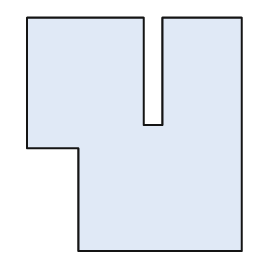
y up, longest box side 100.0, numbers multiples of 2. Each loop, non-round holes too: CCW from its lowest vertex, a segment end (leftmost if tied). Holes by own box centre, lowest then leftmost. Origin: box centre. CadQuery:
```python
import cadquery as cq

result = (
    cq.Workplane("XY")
    .moveTo(-24.0, -50.0)
    .lineTo(46.0, -50.0)
    .lineTo(46.0, 50.0)
    .lineTo(12.0, 50.0)
    .lineTo(12.0, 4.0)
    .lineTo(4.0, 4.0)
    .lineTo(4.0, 50.0)
    .lineTo(-46.0, 50.0)
    .lineTo(-46.0, -6.0)
    .lineTo(-24.0, -6.0)
    .close()
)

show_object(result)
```